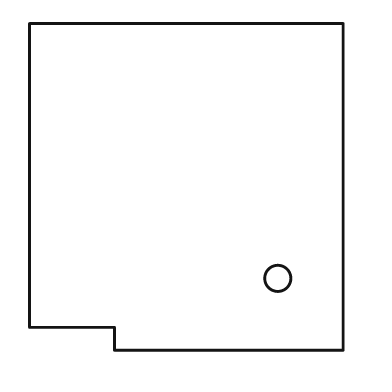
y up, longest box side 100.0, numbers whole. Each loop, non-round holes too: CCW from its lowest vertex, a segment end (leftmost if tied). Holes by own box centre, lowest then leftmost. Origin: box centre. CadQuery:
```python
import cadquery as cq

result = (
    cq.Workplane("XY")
    .moveTo(-22.0, -50.0)
    .lineTo(48.0, -50.0)
    .lineTo(48.0, 50.0)
    .lineTo(-48.0, 50.0)
    .lineTo(-48.0, -43.0)
    .lineTo(-22.0, -43.0)
    .close()
    .moveTo(28.0, -28.0)
    .circle(4.0)
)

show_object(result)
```